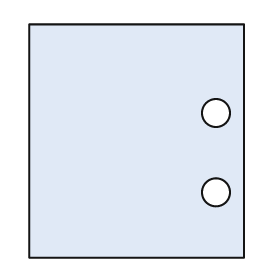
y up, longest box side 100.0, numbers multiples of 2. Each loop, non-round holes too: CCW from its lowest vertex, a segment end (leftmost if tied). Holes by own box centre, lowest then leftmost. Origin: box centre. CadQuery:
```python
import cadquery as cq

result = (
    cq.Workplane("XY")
    .moveTo(-46.0, -50.0)
    .lineTo(46.0, -50.0)
    .lineTo(46.0, 50.0)
    .lineTo(-46.0, 50.0)
    .close()
    .moveTo(34.0, -22.0)
    .circle(6.0)
    .moveTo(34.0, 12.0)
    .circle(6.0)
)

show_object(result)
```